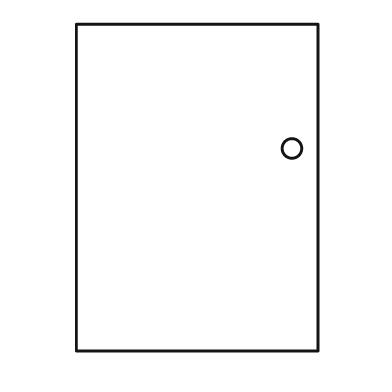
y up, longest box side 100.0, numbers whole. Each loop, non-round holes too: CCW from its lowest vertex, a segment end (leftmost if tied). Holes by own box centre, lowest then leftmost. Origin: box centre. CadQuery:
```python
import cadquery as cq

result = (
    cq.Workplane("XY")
    .moveTo(-37.0, -50.0)
    .lineTo(37.0, -50.0)
    .lineTo(37.0, 50.0)
    .lineTo(-37.0, 50.0)
    .close()
    .moveTo(29.0, 12.0)
    .circle(3.0)
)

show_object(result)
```